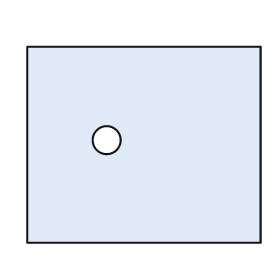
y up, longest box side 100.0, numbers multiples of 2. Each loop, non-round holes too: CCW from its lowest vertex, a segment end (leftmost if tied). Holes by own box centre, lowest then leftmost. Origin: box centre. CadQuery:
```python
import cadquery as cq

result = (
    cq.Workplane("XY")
    .moveTo(-50.0, -42.0)
    .lineTo(50.0, -42.0)
    .lineTo(50.0, 42.0)
    .lineTo(-50.0, 42.0)
    .close()
    .moveTo(-16.0, 2.0)
    .circle(6.0)
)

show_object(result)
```